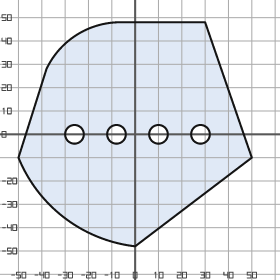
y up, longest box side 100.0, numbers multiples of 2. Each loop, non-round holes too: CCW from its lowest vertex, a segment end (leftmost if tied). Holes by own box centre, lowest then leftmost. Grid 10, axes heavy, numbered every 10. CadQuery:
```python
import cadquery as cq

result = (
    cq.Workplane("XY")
    .moveTo(0.0, -48.0)
    .lineTo(50.0, -10.0)
    .lineTo(30.0, 48.0)
    .lineTo(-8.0, 48.0)
    .threePointArc((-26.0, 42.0), (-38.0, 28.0))
    .lineTo(-50.0, -10.0)
    .threePointArc((-30.0, -36.0), (0.0, -48.0))
    .close()
    .moveTo(-26.0, 0.0)
    .circle(4.0)
    .moveTo(-8.0, 0.0)
    .circle(4.0)
    .moveTo(10.0, 0.0)
    .circle(4.0)
    .moveTo(28.0, 0.0)
    .circle(4.0)
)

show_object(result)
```